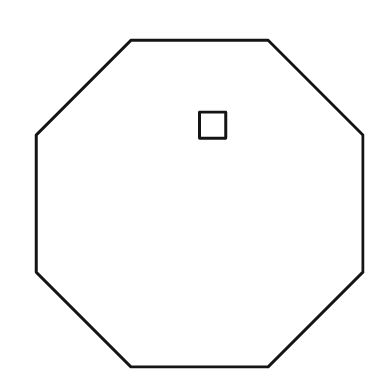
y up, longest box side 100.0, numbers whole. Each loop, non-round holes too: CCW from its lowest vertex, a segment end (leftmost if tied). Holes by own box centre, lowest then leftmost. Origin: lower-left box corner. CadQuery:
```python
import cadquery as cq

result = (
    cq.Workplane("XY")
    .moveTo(29.0, 0.0)
    .lineTo(71.0, 0.0)
    .lineTo(100.0, 29.0)
    .lineTo(100.0, 71.0)
    .lineTo(71.0, 100.0)
    .lineTo(29.0, 100.0)
    .lineTo(0.0, 71.0)
    .lineTo(0.0, 29.0)
    .close()
    .moveTo(50.0, 70.0)
    .lineTo(58.0, 70.0)
    .lineTo(58.0, 78.0)
    .lineTo(50.0, 78.0)
    .close()
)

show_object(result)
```